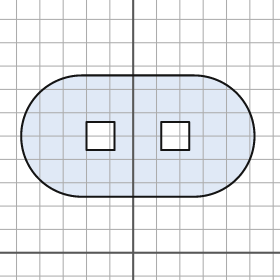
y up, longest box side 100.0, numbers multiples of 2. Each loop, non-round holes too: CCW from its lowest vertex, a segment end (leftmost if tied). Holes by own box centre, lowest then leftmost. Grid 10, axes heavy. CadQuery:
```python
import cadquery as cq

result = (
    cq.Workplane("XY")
    .moveTo(-22.0, 24.0)
    .lineTo(26.0, 24.0)
    .threePointArc((52.0, 50.0), (26.0, 76.0))
    .lineTo(-22.0, 76.0)
    .threePointArc((-48.0, 50.0), (-22.0, 24.0))
    .close()
    .moveTo(-20.0, 44.0)
    .lineTo(-8.0, 44.0)
    .lineTo(-8.0, 56.0)
    .lineTo(-20.0, 56.0)
    .close()
    .moveTo(12.0, 44.0)
    .lineTo(24.0, 44.0)
    .lineTo(24.0, 56.0)
    .lineTo(12.0, 56.0)
    .close()
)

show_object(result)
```